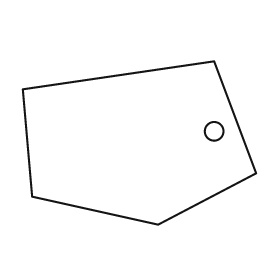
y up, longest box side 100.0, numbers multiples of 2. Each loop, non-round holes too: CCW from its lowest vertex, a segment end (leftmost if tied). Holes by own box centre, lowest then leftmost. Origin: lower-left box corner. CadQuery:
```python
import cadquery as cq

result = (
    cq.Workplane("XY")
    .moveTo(58.0, 0.0)
    .lineTo(100.0, 22.0)
    .lineTo(82.0, 70.0)
    .lineTo(0.0, 58.0)
    .lineTo(4.0, 12.0)
    .close()
    .moveTo(82.0, 40.0)
    .circle(4.0)
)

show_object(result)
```